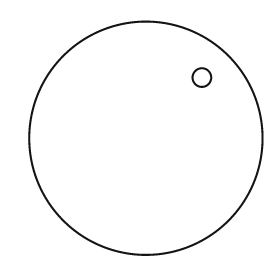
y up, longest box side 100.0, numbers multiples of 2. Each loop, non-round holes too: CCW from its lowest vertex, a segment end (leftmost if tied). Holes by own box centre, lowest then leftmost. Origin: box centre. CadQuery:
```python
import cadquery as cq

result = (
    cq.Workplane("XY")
    .moveTo(0.0, 0.0)
    .circle(50.0)
    .moveTo(24.0, 26.0)
    .circle(4.0)
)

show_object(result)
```